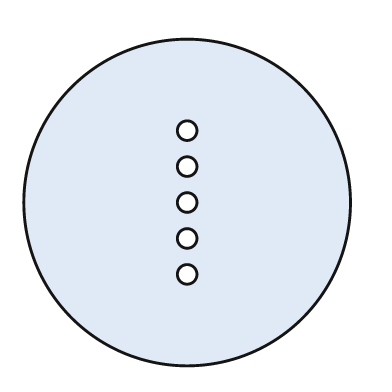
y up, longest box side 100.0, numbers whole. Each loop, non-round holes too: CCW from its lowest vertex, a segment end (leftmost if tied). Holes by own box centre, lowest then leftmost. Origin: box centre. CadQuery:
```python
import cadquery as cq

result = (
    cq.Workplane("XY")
    .moveTo(0.0, 0.0)
    .circle(50.0)
    .moveTo(0.0, -22.0)
    .circle(3.0)
    .moveTo(0.0, -11.0)
    .circle(3.0)
    .moveTo(0.0, 0.0)
    .circle(3.0)
    .moveTo(0.0, 11.0)
    .circle(3.0)
    .moveTo(0.0, 22.0)
    .circle(3.0)
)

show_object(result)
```